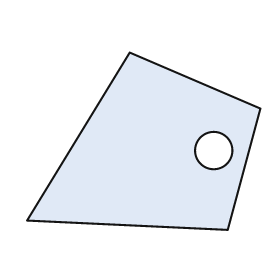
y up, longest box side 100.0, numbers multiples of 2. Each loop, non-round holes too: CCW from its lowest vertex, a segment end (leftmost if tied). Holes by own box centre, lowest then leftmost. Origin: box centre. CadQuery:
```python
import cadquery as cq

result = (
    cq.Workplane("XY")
    .moveTo(36.0, -38.0)
    .lineTo(50.0, 14.0)
    .lineTo(-6.0, 38.0)
    .lineTo(-50.0, -34.0)
    .close()
    .moveTo(30.0, -4.0)
    .circle(8.0)
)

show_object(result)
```